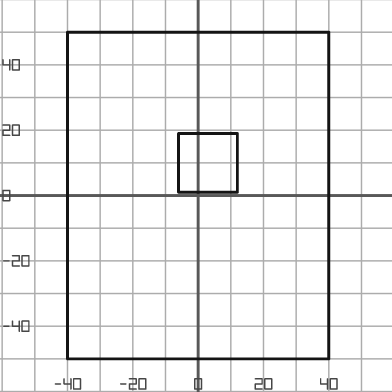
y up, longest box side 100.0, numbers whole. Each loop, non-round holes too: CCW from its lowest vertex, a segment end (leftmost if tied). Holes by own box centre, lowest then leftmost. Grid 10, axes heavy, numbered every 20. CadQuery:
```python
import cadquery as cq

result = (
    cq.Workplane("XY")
    .moveTo(-40.0, -50.0)
    .lineTo(40.0, -50.0)
    .lineTo(40.0, 50.0)
    .lineTo(-40.0, 50.0)
    .close()
    .moveTo(-6.0, 1.0)
    .lineTo(12.0, 1.0)
    .lineTo(12.0, 19.0)
    .lineTo(-6.0, 19.0)
    .close()
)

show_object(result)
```